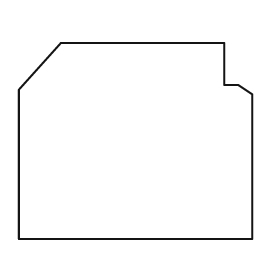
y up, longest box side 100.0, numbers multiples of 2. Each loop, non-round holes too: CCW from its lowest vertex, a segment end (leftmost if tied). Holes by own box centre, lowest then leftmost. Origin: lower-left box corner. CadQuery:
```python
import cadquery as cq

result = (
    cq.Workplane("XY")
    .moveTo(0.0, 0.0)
    .lineTo(100.0, 0.0)
    .lineTo(100.0, 62.0)
    .lineTo(94.0, 66.0)
    .lineTo(88.0, 66.0)
    .lineTo(88.0, 84.0)
    .lineTo(18.0, 84.0)
    .lineTo(0.0, 64.0)
    .close()
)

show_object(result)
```